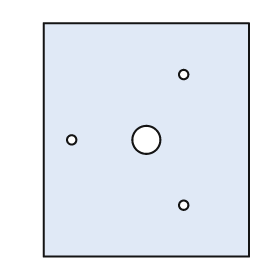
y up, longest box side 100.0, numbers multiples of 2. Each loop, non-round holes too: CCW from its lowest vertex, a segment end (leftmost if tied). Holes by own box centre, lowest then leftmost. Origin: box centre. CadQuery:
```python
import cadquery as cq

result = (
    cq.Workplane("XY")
    .moveTo(-44.0, -50.0)
    .lineTo(44.0, -50.0)
    .lineTo(44.0, 50.0)
    .lineTo(-44.0, 50.0)
    .close()
    .moveTo(16.0, -28.0)
    .circle(2.0)
    .moveTo(-32.0, 0.0)
    .circle(2.0)
    .moveTo(0.0, 0.0)
    .circle(6.0)
    .moveTo(16.0, 28.0)
    .circle(2.0)
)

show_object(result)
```